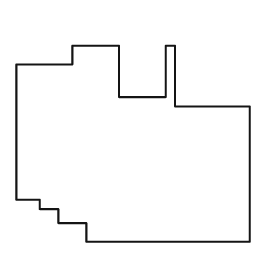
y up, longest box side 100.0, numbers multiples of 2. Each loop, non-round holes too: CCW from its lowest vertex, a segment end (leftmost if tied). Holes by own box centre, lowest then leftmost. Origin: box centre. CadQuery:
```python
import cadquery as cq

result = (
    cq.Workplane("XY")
    .moveTo(-20.0, -42.0)
    .lineTo(50.0, -42.0)
    .lineTo(50.0, 16.0)
    .lineTo(18.0, 16.0)
    .lineTo(18.0, 42.0)
    .lineTo(14.0, 42.0)
    .lineTo(14.0, 20.0)
    .lineTo(-6.0, 20.0)
    .lineTo(-6.0, 42.0)
    .lineTo(-26.0, 42.0)
    .lineTo(-26.0, 34.0)
    .lineTo(-50.0, 34.0)
    .lineTo(-50.0, -24.0)
    .lineTo(-40.0, -24.0)
    .lineTo(-40.0, -28.0)
    .lineTo(-32.0, -28.0)
    .lineTo(-32.0, -34.0)
    .lineTo(-20.0, -34.0)
    .close()
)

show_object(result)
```